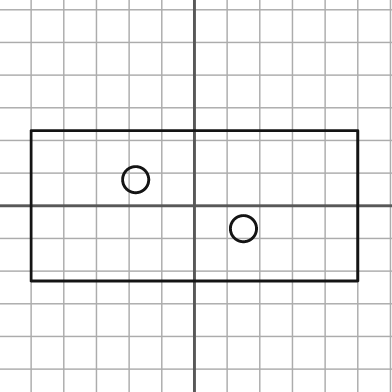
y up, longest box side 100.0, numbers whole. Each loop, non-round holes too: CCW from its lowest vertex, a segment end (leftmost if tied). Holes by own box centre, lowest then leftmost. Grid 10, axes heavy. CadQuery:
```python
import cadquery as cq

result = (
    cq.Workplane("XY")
    .moveTo(-50.0, -23.0)
    .lineTo(50.0, -23.0)
    .lineTo(50.0, 23.0)
    .lineTo(-50.0, 23.0)
    .close()
    .moveTo(15.0, -7.0)
    .circle(4.0)
    .moveTo(-18.0, 8.0)
    .circle(4.0)
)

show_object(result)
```